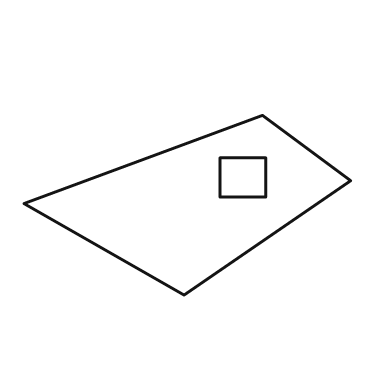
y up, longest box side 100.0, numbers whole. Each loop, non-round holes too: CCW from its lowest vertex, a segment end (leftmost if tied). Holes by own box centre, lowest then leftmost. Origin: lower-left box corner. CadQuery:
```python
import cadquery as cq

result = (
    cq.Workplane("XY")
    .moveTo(49.0, 0.0)
    .lineTo(100.0, 35.0)
    .lineTo(73.0, 55.0)
    .lineTo(0.0, 28.0)
    .close()
    .moveTo(60.0, 30.0)
    .lineTo(74.0, 30.0)
    .lineTo(74.0, 42.0)
    .lineTo(60.0, 42.0)
    .close()
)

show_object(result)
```